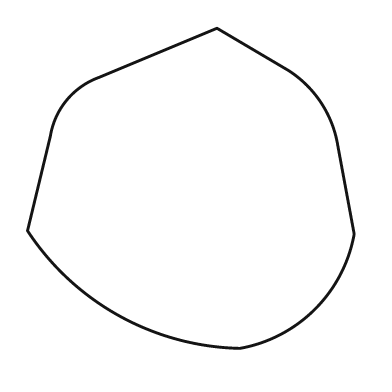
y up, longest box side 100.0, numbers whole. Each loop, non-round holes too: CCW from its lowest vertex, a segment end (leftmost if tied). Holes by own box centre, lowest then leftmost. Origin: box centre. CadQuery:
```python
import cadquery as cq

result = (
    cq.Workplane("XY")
    .moveTo(15.0, -49.0)
    .threePointArc((38.0, -37.0), (50.0, -14.0))
    .lineTo(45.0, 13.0)
    .threePointArc((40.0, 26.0), (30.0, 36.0))
    .lineTo(8.0, 49.0)
    .lineTo(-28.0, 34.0)
    .threePointArc((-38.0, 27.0), (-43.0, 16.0))
    .lineTo(-50.0, -13.0)
    .threePointArc((-22.0, -39.0), (15.0, -49.0))
    .close()
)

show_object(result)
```